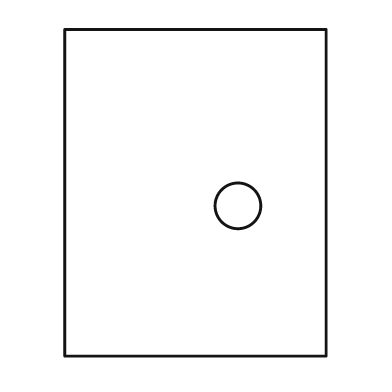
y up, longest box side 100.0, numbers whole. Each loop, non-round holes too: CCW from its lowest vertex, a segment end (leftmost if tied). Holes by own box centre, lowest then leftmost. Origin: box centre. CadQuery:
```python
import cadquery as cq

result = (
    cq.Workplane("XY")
    .moveTo(-40.0, -50.0)
    .lineTo(40.0, -50.0)
    .lineTo(40.0, 50.0)
    .lineTo(-40.0, 50.0)
    .close()
    .moveTo(13.0, -4.0)
    .circle(7.0)
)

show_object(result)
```